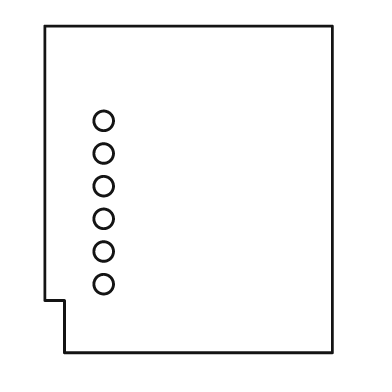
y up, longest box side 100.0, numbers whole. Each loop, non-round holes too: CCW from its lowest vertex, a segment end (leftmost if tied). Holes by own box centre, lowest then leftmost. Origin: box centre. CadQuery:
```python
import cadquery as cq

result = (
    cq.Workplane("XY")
    .moveTo(-38.0, -50.0)
    .lineTo(44.0, -50.0)
    .lineTo(44.0, 50.0)
    .lineTo(-44.0, 50.0)
    .lineTo(-44.0, -34.0)
    .lineTo(-38.0, -34.0)
    .close()
    .moveTo(-26.0, -29.0)
    .circle(3.0)
    .moveTo(-26.0, -19.0)
    .circle(3.0)
    .moveTo(-26.0, -9.0)
    .circle(3.0)
    .moveTo(-26.0, 1.0)
    .circle(3.0)
    .moveTo(-26.0, 11.0)
    .circle(3.0)
    .moveTo(-26.0, 21.0)
    .circle(3.0)
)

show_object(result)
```